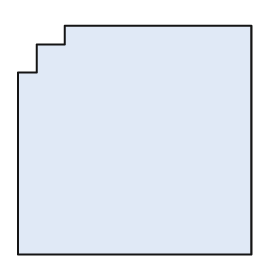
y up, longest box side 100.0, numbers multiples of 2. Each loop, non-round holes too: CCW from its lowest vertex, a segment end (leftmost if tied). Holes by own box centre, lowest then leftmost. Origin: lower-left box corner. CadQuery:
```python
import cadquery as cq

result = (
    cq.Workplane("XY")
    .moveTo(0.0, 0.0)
    .lineTo(100.0, 0.0)
    .lineTo(100.0, 98.0)
    .lineTo(20.0, 98.0)
    .lineTo(20.0, 90.0)
    .lineTo(8.0, 90.0)
    .lineTo(8.0, 78.0)
    .lineTo(0.0, 78.0)
    .close()
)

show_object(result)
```